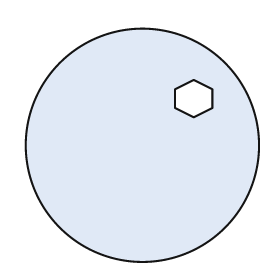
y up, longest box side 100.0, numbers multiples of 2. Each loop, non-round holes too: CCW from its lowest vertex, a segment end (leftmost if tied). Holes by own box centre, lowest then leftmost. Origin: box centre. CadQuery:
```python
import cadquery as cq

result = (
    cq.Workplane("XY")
    .moveTo(0.0, 0.0)
    .circle(50.0)
    .moveTo(22.0, 12.0)
    .lineTo(30.0, 16.0)
    .lineTo(30.0, 24.0)
    .lineTo(22.0, 28.0)
    .lineTo(14.0, 24.0)
    .lineTo(14.0, 16.0)
    .close()
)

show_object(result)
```